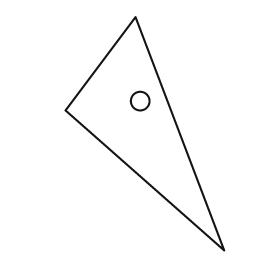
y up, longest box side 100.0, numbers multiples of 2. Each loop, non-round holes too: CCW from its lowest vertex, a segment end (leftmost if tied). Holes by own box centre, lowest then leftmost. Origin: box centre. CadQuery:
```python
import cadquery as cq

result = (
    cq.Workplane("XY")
    .moveTo(34.0, -50.0)
    .lineTo(-4.0, 50.0)
    .lineTo(-34.0, 10.0)
    .close()
    .moveTo(-2.0, 14.0)
    .circle(4.0)
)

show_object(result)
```